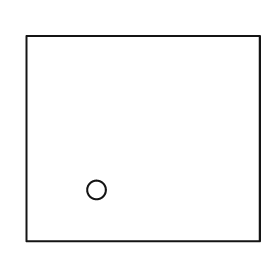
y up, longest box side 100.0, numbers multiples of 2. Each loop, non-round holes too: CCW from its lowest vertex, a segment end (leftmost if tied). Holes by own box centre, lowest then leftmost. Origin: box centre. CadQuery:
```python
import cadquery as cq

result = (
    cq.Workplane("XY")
    .moveTo(-50.0, -44.0)
    .lineTo(50.0, -44.0)
    .lineTo(50.0, 44.0)
    .lineTo(-50.0, 44.0)
    .close()
    .moveTo(-20.0, -22.0)
    .circle(4.0)
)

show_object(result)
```